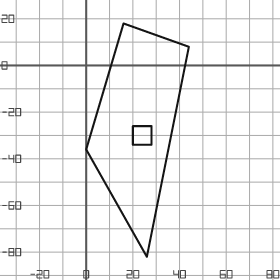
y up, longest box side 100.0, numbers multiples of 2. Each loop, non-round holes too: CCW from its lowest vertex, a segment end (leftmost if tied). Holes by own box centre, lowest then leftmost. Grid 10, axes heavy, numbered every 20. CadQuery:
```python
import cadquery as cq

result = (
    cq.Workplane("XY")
    .moveTo(26.0, -82.0)
    .lineTo(44.0, 8.0)
    .lineTo(16.0, 18.0)
    .lineTo(0.0, -36.0)
    .close()
    .moveTo(20.0, -34.0)
    .lineTo(28.0, -34.0)
    .lineTo(28.0, -26.0)
    .lineTo(20.0, -26.0)
    .close()
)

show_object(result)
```